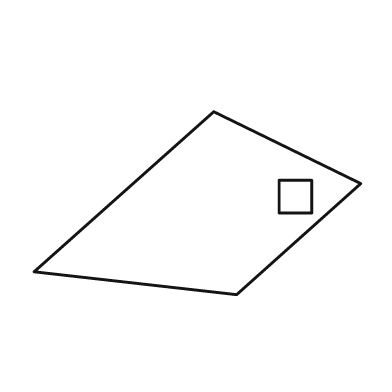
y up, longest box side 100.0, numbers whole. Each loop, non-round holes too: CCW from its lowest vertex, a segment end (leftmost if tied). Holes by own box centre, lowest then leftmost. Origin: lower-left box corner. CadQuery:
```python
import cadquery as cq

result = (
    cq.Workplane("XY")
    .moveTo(62.0, 0.0)
    .lineTo(100.0, 34.0)
    .lineTo(55.0, 56.0)
    .lineTo(0.0, 7.0)
    .close()
    .moveTo(75.0, 25.0)
    .lineTo(85.0, 25.0)
    .lineTo(85.0, 35.0)
    .lineTo(75.0, 35.0)
    .close()
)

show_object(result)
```